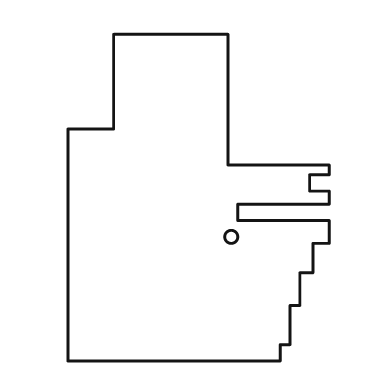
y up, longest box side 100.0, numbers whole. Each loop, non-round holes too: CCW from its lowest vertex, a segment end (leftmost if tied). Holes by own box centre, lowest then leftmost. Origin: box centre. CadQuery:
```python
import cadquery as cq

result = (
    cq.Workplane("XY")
    .moveTo(-40.0, -50.0)
    .lineTo(25.0, -50.0)
    .lineTo(25.0, -45.0)
    .lineTo(28.0, -45.0)
    .lineTo(28.0, -33.0)
    .lineTo(31.0, -33.0)
    .lineTo(31.0, -23.0)
    .lineTo(35.0, -23.0)
    .lineTo(35.0, -14.0)
    .lineTo(40.0, -14.0)
    .lineTo(40.0, -7.0)
    .lineTo(12.0, -7.0)
    .lineTo(12.0, -2.0)
    .lineTo(40.0, -2.0)
    .lineTo(40.0, 2.0)
    .lineTo(34.0, 2.0)
    .lineTo(34.0, 7.0)
    .lineTo(40.0, 7.0)
    .lineTo(40.0, 10.0)
    .lineTo(9.0, 10.0)
    .lineTo(9.0, 50.0)
    .lineTo(-26.0, 50.0)
    .lineTo(-26.0, 21.0)
    .lineTo(-40.0, 21.0)
    .close()
    .moveTo(10.0, -12.0)
    .circle(2.0)
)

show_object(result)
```